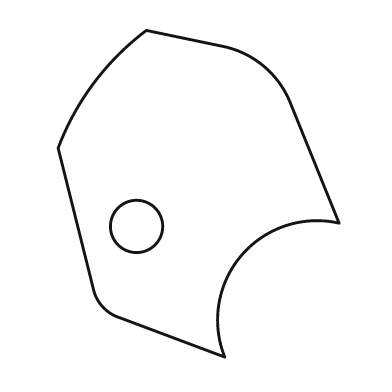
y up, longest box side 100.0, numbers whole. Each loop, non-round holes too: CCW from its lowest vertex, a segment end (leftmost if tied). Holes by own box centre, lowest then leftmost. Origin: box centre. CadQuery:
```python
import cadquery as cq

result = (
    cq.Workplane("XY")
    .moveTo(8.0, -50.0)
    .threePointArc((13.0, -19.0), (43.0, -9.0))
    .lineTo(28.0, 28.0)
    .threePointArc((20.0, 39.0), (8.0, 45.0))
    .lineTo(-16.0, 50.0)
    .threePointArc((-32.0, 34.0), (-43.0, 14.0))
    .lineTo(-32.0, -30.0)
    .threePointArc((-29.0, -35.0), (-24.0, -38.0))
    .close()
    .moveTo(-19.0, -10.0)
    .circle(8.0)
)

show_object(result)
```